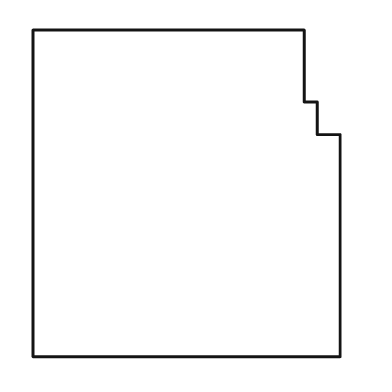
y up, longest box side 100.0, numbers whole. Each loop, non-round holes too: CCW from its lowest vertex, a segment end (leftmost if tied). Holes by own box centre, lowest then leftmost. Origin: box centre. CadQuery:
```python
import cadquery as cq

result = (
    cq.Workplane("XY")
    .moveTo(-47.0, -50.0)
    .lineTo(47.0, -50.0)
    .lineTo(47.0, 18.0)
    .lineTo(40.0, 18.0)
    .lineTo(40.0, 28.0)
    .lineTo(36.0, 28.0)
    .lineTo(36.0, 50.0)
    .lineTo(-47.0, 50.0)
    .close()
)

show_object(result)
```